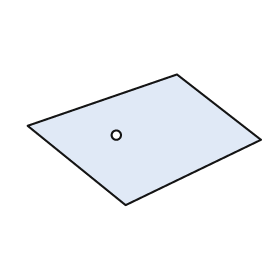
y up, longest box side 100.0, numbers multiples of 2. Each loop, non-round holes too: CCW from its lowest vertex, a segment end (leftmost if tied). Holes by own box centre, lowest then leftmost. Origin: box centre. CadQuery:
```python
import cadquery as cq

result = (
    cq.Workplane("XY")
    .moveTo(-8.0, -28.0)
    .lineTo(50.0, 0.0)
    .lineTo(14.0, 28.0)
    .lineTo(-50.0, 6.0)
    .close()
    .moveTo(-12.0, 2.0)
    .circle(2.0)
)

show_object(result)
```